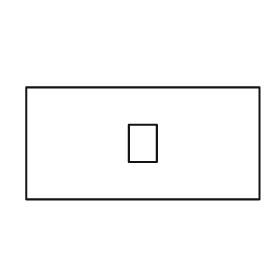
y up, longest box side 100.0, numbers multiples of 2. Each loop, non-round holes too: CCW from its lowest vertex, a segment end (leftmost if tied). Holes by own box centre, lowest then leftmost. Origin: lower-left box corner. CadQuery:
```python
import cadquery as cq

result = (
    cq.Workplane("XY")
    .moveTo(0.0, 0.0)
    .lineTo(100.0, 0.0)
    .lineTo(100.0, 48.0)
    .lineTo(0.0, 48.0)
    .close()
    .moveTo(44.0, 16.0)
    .lineTo(56.0, 16.0)
    .lineTo(56.0, 32.0)
    .lineTo(44.0, 32.0)
    .close()
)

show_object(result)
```